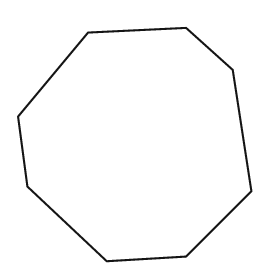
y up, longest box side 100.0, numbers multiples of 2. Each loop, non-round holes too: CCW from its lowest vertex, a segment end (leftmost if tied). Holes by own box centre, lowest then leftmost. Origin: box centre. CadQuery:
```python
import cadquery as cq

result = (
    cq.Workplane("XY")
    .moveTo(-12.0, -50.0)
    .lineTo(22.0, -48.0)
    .lineTo(50.0, -20.0)
    .lineTo(42.0, 32.0)
    .lineTo(22.0, 50.0)
    .lineTo(-20.0, 48.0)
    .lineTo(-50.0, 12.0)
    .lineTo(-46.0, -18.0)
    .close()
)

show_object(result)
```